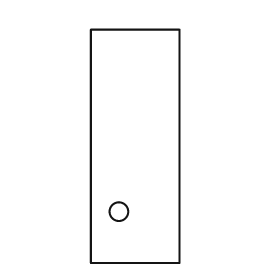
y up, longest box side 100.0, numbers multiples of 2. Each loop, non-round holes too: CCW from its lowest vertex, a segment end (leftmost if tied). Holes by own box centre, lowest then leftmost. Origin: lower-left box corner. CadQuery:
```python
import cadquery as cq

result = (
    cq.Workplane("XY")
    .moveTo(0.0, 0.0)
    .lineTo(38.0, 0.0)
    .lineTo(38.0, 100.0)
    .lineTo(0.0, 100.0)
    .close()
    .moveTo(12.0, 22.0)
    .circle(4.0)
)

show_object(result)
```